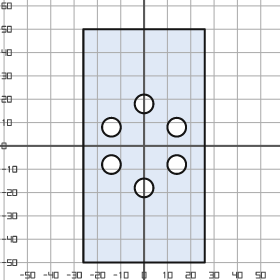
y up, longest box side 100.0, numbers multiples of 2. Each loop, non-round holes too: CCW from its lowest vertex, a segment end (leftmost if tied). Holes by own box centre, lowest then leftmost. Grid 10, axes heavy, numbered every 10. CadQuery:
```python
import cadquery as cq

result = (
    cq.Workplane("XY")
    .moveTo(-26.0, -50.0)
    .lineTo(26.0, -50.0)
    .lineTo(26.0, 50.0)
    .lineTo(-26.0, 50.0)
    .close()
    .moveTo(0.0, -18.0)
    .circle(4.0)
    .moveTo(-14.0, -8.0)
    .circle(4.0)
    .moveTo(14.0, -8.0)
    .circle(4.0)
    .moveTo(-14.0, 8.0)
    .circle(4.0)
    .moveTo(14.0, 8.0)
    .circle(4.0)
    .moveTo(0.0, 18.0)
    .circle(4.0)
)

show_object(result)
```